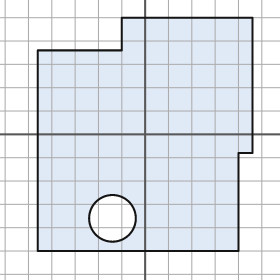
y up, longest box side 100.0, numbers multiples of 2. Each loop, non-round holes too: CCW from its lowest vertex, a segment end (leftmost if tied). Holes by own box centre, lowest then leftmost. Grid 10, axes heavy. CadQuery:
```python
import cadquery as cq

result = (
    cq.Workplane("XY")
    .moveTo(-46.0, -50.0)
    .lineTo(40.0, -50.0)
    .lineTo(40.0, -8.0)
    .lineTo(46.0, -8.0)
    .lineTo(46.0, 50.0)
    .lineTo(-10.0, 50.0)
    .lineTo(-10.0, 36.0)
    .lineTo(-46.0, 36.0)
    .close()
    .moveTo(-14.0, -36.0)
    .circle(10.0)
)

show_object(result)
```